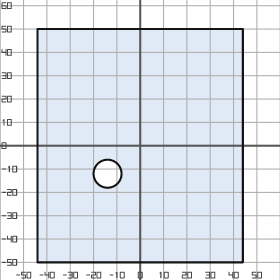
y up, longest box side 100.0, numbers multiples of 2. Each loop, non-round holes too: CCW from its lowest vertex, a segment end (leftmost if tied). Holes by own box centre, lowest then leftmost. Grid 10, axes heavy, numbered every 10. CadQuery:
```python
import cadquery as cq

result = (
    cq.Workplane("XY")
    .moveTo(-44.0, -50.0)
    .lineTo(44.0, -50.0)
    .lineTo(44.0, 50.0)
    .lineTo(-44.0, 50.0)
    .close()
    .moveTo(-14.0, -12.0)
    .circle(6.0)
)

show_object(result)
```